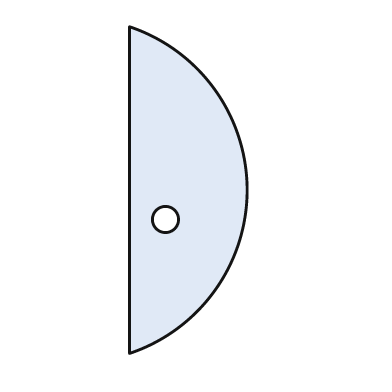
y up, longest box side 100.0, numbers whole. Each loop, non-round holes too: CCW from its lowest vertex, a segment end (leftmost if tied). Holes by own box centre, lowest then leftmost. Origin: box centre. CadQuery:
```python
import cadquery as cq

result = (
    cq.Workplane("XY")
    .moveTo(-18.0, -50.0)
    .threePointArc((18.0, 0.0), (-18.0, 50.0))
    .close()
    .moveTo(-7.0, -9.0)
    .circle(4.0)
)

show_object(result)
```